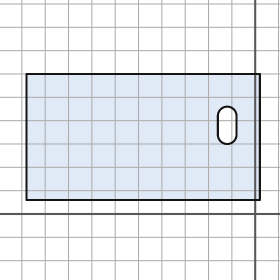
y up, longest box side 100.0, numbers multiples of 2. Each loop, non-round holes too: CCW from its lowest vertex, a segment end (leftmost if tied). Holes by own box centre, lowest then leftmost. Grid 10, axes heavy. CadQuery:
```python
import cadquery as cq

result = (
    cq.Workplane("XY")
    .moveTo(-98.0, 6.0)
    .lineTo(2.0, 6.0)
    .lineTo(2.0, 60.0)
    .lineTo(-98.0, 60.0)
    .close()
    .moveTo(-16.0, 34.0)
    .threePointArc((-12.0, 30.0), (-8.0, 34.0))
    .lineTo(-8.0, 42.0)
    .threePointArc((-12.0, 46.0), (-16.0, 42.0))
    .close()
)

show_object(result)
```